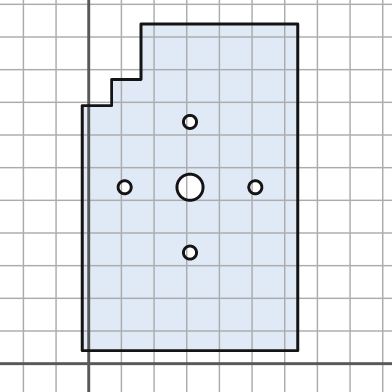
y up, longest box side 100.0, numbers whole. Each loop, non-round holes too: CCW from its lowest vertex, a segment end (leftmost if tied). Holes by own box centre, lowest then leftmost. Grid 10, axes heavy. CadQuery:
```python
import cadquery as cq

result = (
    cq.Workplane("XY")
    .moveTo(-2.0, 4.0)
    .lineTo(64.0, 4.0)
    .lineTo(64.0, 104.0)
    .lineTo(16.0, 104.0)
    .lineTo(16.0, 87.0)
    .lineTo(7.0, 87.0)
    .lineTo(7.0, 79.0)
    .lineTo(-2.0, 79.0)
    .close()
    .moveTo(31.0, 34.0)
    .circle(2.0)
    .moveTo(11.0, 54.0)
    .circle(2.0)
    .moveTo(31.0, 54.0)
    .circle(4.0)
    .moveTo(51.0, 54.0)
    .circle(2.0)
    .moveTo(31.0, 74.0)
    .circle(2.0)
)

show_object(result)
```